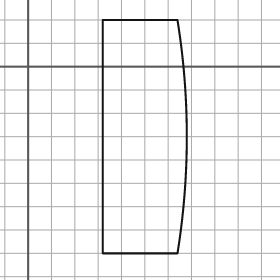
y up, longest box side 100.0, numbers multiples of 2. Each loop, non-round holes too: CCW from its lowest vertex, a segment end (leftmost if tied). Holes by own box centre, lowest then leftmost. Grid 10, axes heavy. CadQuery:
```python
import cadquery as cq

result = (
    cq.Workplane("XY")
    .moveTo(32.0, -80.0)
    .lineTo(64.0, -80.0)
    .threePointArc((68.0, -30.0), (64.0, 20.0))
    .lineTo(32.0, 20.0)
    .close()
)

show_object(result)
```